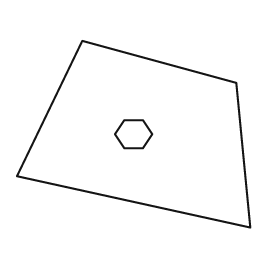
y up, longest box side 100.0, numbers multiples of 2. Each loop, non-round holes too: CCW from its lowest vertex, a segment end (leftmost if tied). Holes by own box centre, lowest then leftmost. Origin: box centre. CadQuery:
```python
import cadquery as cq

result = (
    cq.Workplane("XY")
    .moveTo(50.0, -40.0)
    .lineTo(44.0, 22.0)
    .lineTo(-22.0, 40.0)
    .lineTo(-50.0, -18.0)
    .close()
    .moveTo(-4.0, -6.0)
    .lineTo(4.0, -6.0)
    .lineTo(8.0, 0.0)
    .lineTo(4.0, 6.0)
    .lineTo(-4.0, 6.0)
    .lineTo(-8.0, 0.0)
    .close()
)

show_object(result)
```